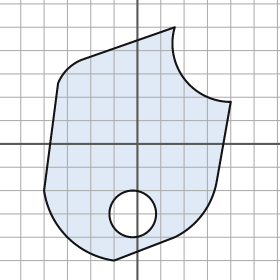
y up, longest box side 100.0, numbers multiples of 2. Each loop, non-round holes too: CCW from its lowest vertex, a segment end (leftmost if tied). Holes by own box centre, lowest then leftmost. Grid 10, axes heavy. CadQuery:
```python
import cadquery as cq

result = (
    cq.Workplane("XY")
    .moveTo(-10.0, -50.0)
    .lineTo(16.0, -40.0)
    .threePointArc((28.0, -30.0), (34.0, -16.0))
    .lineTo(40.0, 18.0)
    .threePointArc((20.0, 28.0), (16.0, 50.0))
    .lineTo(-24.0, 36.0)
    .threePointArc((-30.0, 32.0), (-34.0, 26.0))
    .lineTo(-40.0, -20.0)
    .threePointArc((-30.0, -40.0), (-10.0, -50.0))
    .close()
    .moveTo(-2.0, -30.0)
    .circle(10.0)
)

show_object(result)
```